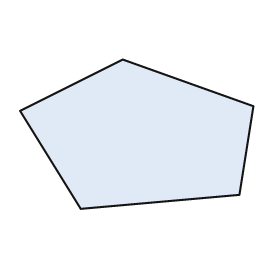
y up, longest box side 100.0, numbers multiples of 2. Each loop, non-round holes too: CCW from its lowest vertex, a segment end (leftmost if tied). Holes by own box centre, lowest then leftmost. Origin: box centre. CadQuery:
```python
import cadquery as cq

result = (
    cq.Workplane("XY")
    .moveTo(-24.0, -32.0)
    .lineTo(44.0, -26.0)
    .lineTo(50.0, 12.0)
    .lineTo(-6.0, 32.0)
    .lineTo(-50.0, 10.0)
    .close()
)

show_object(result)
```